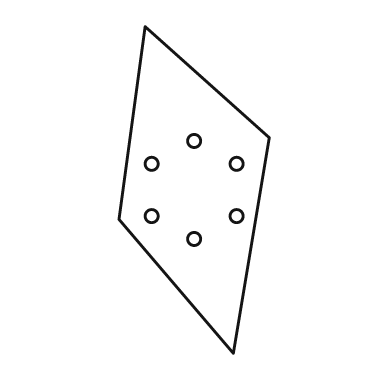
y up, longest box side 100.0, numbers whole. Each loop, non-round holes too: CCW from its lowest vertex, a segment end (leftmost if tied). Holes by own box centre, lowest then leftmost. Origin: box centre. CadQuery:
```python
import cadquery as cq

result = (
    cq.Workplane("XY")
    .moveTo(12.0, -50.0)
    .lineTo(23.0, 16.0)
    .lineTo(-15.0, 50.0)
    .lineTo(-23.0, -9.0)
    .close()
    .moveTo(0.0, -15.0)
    .circle(2.0)
    .moveTo(-13.0, -8.0)
    .circle(2.0)
    .moveTo(13.0, -8.0)
    .circle(2.0)
    .moveTo(-13.0, 8.0)
    .circle(2.0)
    .moveTo(13.0, 8.0)
    .circle(2.0)
    .moveTo(0.0, 15.0)
    .circle(2.0)
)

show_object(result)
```